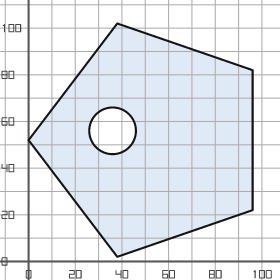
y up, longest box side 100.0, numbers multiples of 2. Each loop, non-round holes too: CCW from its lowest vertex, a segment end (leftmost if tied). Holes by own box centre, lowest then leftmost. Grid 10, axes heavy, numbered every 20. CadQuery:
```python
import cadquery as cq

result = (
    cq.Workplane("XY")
    .moveTo(38.0, 2.0)
    .lineTo(96.0, 22.0)
    .lineTo(96.0, 82.0)
    .lineTo(38.0, 102.0)
    .lineTo(0.0, 52.0)
    .close()
    .moveTo(36.0, 56.0)
    .circle(10.0)
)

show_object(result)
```